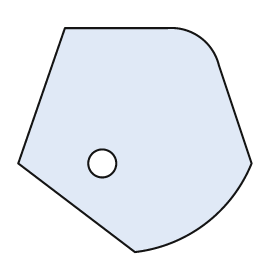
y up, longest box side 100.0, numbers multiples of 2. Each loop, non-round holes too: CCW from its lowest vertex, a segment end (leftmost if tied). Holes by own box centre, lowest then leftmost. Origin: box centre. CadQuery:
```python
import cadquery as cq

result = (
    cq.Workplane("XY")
    .moveTo(0.0, -48.0)
    .threePointArc((30.0, -36.0), (50.0, -10.0))
    .lineTo(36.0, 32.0)
    .threePointArc((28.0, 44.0), (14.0, 48.0))
    .lineTo(-30.0, 48.0)
    .lineTo(-50.0, -10.0)
    .close()
    .moveTo(-14.0, -10.0)
    .circle(6.0)
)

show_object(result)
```